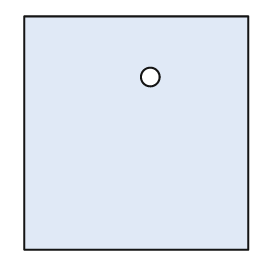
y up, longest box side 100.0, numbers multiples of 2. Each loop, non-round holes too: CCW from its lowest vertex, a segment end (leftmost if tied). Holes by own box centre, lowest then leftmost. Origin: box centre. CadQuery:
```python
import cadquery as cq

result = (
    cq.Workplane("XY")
    .moveTo(-48.0, -50.0)
    .lineTo(48.0, -50.0)
    .lineTo(48.0, 50.0)
    .lineTo(-48.0, 50.0)
    .close()
    .moveTo(6.0, 24.0)
    .circle(4.0)
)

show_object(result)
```